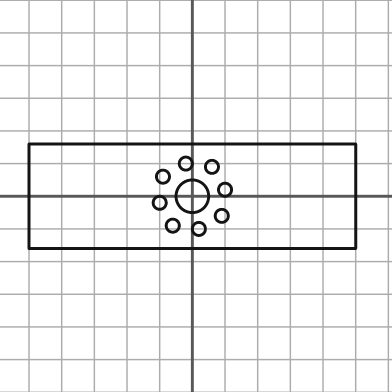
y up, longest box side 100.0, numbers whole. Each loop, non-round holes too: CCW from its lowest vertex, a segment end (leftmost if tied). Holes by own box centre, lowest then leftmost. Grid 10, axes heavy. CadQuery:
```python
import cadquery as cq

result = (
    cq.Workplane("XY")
    .moveTo(-50.0, -16.0)
    .lineTo(50.0, -16.0)
    .lineTo(50.0, 16.0)
    .lineTo(-50.0, 16.0)
    .close()
    .moveTo(2.0, -10.0)
    .circle(2.0)
    .moveTo(-6.0, -9.0)
    .circle(2.0)
    .moveTo(9.0, -6.0)
    .circle(2.0)
    .moveTo(-10.0, -2.0)
    .circle(2.0)
    .moveTo(0.0, 0.0)
    .circle(5.0)
    .moveTo(10.0, 2.0)
    .circle(2.0)
    .moveTo(-9.0, 6.0)
    .circle(2.0)
    .moveTo(6.0, 9.0)
    .circle(2.0)
    .moveTo(-2.0, 10.0)
    .circle(2.0)
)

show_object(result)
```